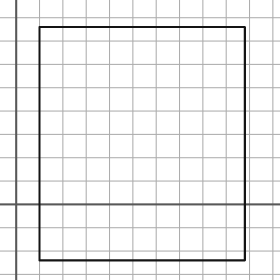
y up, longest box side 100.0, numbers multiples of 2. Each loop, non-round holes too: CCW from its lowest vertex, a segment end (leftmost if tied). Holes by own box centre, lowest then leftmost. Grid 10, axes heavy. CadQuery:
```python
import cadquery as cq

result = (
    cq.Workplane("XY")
    .moveTo(10.0, -24.0)
    .lineTo(98.0, -24.0)
    .lineTo(98.0, 76.0)
    .lineTo(10.0, 76.0)
    .close()
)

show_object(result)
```